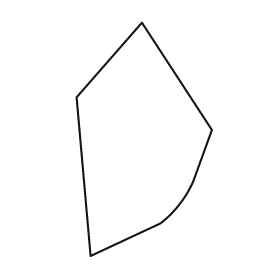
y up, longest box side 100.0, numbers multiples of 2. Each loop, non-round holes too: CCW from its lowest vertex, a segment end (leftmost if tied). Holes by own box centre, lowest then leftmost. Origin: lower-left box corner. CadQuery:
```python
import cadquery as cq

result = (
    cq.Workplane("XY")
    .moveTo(6.0, 0.0)
    .lineTo(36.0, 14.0)
    .threePointArc((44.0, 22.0), (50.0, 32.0))
    .lineTo(58.0, 54.0)
    .lineTo(28.0, 100.0)
    .lineTo(0.0, 68.0)
    .close()
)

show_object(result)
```